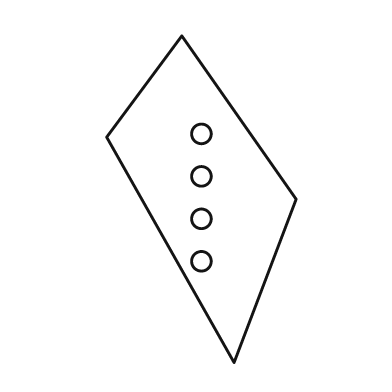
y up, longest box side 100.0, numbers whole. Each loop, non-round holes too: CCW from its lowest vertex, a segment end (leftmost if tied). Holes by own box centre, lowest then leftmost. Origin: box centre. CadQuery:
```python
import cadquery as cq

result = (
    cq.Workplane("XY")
    .moveTo(10.0, -50.0)
    .lineTo(29.0, 0.0)
    .lineTo(-6.0, 50.0)
    .lineTo(-29.0, 19.0)
    .close()
    .moveTo(0.0, -19.0)
    .circle(3.0)
    .moveTo(0.0, -6.0)
    .circle(3.0)
    .moveTo(0.0, 7.0)
    .circle(3.0)
    .moveTo(0.0, 20.0)
    .circle(3.0)
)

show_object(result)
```